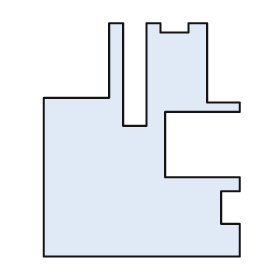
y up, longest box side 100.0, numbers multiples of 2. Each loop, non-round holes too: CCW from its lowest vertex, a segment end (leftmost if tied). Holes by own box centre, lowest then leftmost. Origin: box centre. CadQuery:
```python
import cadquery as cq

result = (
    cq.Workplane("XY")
    .moveTo(-42.0, -50.0)
    .lineTo(42.0, -50.0)
    .lineTo(42.0, -36.0)
    .lineTo(34.0, -36.0)
    .lineTo(34.0, -22.0)
    .lineTo(42.0, -22.0)
    .lineTo(42.0, -16.0)
    .lineTo(10.0, -16.0)
    .lineTo(10.0, 12.0)
    .lineTo(42.0, 12.0)
    .lineTo(42.0, 16.0)
    .lineTo(28.0, 16.0)
    .lineTo(28.0, 50.0)
    .lineTo(20.0, 50.0)
    .lineTo(20.0, 46.0)
    .lineTo(8.0, 46.0)
    .lineTo(8.0, 50.0)
    .lineTo(2.0, 50.0)
    .lineTo(2.0, 6.0)
    .lineTo(-8.0, 6.0)
    .lineTo(-8.0, 50.0)
    .lineTo(-14.0, 50.0)
    .lineTo(-14.0, 18.0)
    .lineTo(-42.0, 18.0)
    .close()
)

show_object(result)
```